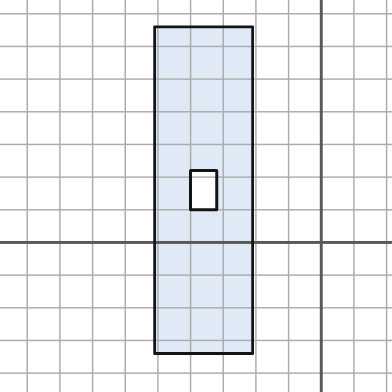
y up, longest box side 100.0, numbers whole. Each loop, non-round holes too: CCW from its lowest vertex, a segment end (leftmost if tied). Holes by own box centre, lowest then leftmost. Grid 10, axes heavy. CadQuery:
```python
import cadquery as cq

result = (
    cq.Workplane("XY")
    .moveTo(-51.0, -34.0)
    .lineTo(-21.0, -34.0)
    .lineTo(-21.0, 66.0)
    .lineTo(-51.0, 66.0)
    .close()
    .moveTo(-40.0, 10.0)
    .lineTo(-32.0, 10.0)
    .lineTo(-32.0, 22.0)
    .lineTo(-40.0, 22.0)
    .close()
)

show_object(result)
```